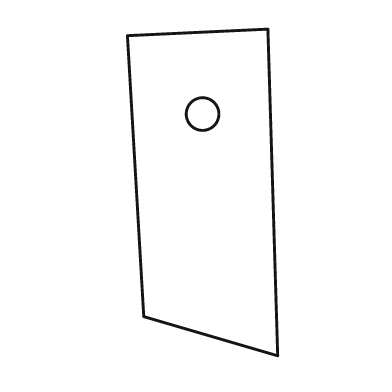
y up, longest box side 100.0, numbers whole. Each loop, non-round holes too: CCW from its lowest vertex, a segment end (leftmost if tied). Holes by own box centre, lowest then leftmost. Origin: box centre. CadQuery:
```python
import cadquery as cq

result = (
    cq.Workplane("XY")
    .moveTo(23.0, -50.0)
    .lineTo(20.0, 50.0)
    .lineTo(-23.0, 48.0)
    .lineTo(-18.0, -38.0)
    .close()
    .moveTo(0.0, 24.0)
    .circle(5.0)
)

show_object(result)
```